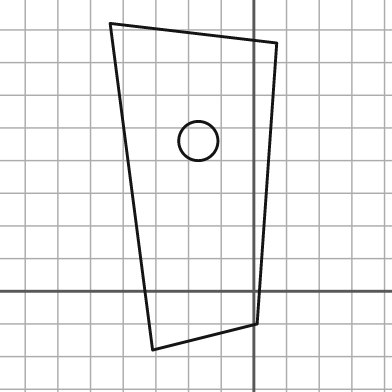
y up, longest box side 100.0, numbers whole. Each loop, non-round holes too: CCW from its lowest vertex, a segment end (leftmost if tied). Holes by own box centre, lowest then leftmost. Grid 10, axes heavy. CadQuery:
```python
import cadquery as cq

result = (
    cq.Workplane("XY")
    .moveTo(-31.0, -18.0)
    .lineTo(1.0, -10.0)
    .lineTo(7.0, 76.0)
    .lineTo(-44.0, 82.0)
    .close()
    .moveTo(-17.0, 46.0)
    .circle(6.0)
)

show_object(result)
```